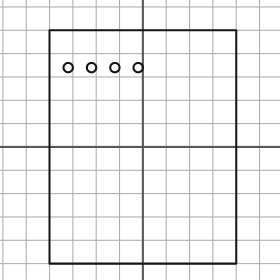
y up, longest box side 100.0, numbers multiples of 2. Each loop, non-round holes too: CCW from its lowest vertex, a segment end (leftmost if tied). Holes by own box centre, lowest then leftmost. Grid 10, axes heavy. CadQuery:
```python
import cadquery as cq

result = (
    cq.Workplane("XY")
    .moveTo(-40.0, -50.0)
    .lineTo(40.0, -50.0)
    .lineTo(40.0, 50.0)
    .lineTo(-40.0, 50.0)
    .close()
    .moveTo(-32.0, 34.0)
    .circle(2.0)
    .moveTo(-22.0, 34.0)
    .circle(2.0)
    .moveTo(-12.0, 34.0)
    .circle(2.0)
    .moveTo(-2.0, 34.0)
    .circle(2.0)
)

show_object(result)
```